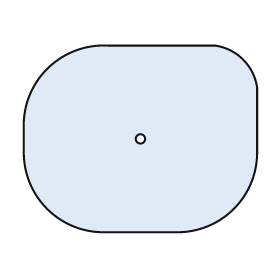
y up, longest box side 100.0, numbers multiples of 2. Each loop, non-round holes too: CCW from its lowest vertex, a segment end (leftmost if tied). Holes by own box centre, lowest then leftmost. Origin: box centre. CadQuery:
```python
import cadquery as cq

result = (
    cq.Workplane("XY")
    .moveTo(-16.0, -40.0)
    .lineTo(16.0, -40.0)
    .threePointArc((40.0, -30.0), (50.0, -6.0))
    .lineTo(50.0, 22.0)
    .threePointArc((44.0, 34.0), (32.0, 40.0))
    .lineTo(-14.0, 40.0)
    .threePointArc((-40.0, 30.0), (-50.0, 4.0))
    .lineTo(-50.0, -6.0)
    .threePointArc((-40.0, -30.0), (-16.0, -40.0))
    .close()
    .moveTo(0.0, 0.0)
    .circle(2.0)
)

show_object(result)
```